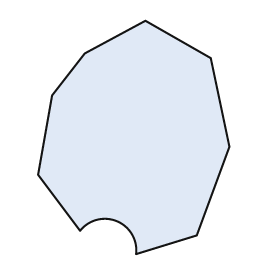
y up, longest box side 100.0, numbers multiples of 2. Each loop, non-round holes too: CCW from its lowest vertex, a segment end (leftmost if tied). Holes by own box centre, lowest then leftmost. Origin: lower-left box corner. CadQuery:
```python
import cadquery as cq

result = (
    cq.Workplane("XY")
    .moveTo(42.0, 0.0)
    .lineTo(68.0, 8.0)
    .lineTo(82.0, 46.0)
    .lineTo(74.0, 84.0)
    .lineTo(46.0, 100.0)
    .lineTo(20.0, 86.0)
    .lineTo(6.0, 68.0)
    .lineTo(0.0, 34.0)
    .lineTo(18.0, 10.0)
    .threePointArc((34.0, 14.0), (42.0, 0.0))
    .close()
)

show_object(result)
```